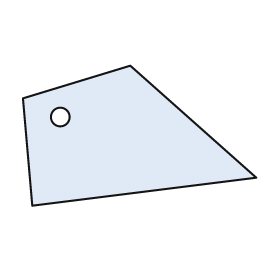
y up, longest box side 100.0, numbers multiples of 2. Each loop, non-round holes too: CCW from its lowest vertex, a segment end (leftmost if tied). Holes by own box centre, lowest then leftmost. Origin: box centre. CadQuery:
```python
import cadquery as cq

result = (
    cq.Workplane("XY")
    .moveTo(-46.0, -30.0)
    .lineTo(50.0, -18.0)
    .lineTo(-4.0, 30.0)
    .lineTo(-50.0, 16.0)
    .close()
    .moveTo(-34.0, 8.0)
    .circle(4.0)
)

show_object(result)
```